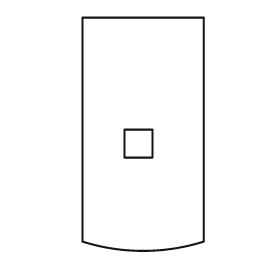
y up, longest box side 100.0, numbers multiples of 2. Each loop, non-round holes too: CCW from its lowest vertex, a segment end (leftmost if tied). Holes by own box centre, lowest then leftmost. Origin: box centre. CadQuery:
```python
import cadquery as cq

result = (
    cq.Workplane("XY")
    .moveTo(-26.0, -46.0)
    .threePointArc((0.0, -50.0), (26.0, -46.0))
    .lineTo(26.0, 50.0)
    .lineTo(-26.0, 50.0)
    .close()
    .moveTo(-8.0, -10.0)
    .lineTo(4.0, -10.0)
    .lineTo(4.0, 2.0)
    .lineTo(-8.0, 2.0)
    .close()
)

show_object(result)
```